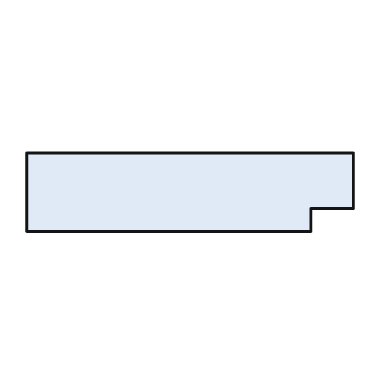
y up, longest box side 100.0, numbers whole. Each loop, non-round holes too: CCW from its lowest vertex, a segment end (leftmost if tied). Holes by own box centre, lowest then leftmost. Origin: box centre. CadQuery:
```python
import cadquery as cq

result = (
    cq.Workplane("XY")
    .moveTo(-50.0, -12.0)
    .lineTo(37.0, -12.0)
    .lineTo(37.0, -5.0)
    .lineTo(50.0, -5.0)
    .lineTo(50.0, 12.0)
    .lineTo(-50.0, 12.0)
    .close()
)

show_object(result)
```